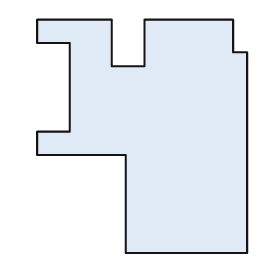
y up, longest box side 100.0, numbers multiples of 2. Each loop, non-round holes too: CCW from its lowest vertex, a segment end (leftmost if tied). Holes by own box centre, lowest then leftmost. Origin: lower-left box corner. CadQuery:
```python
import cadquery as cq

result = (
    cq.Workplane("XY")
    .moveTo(38.0, 0.0)
    .lineTo(90.0, 0.0)
    .lineTo(90.0, 86.0)
    .lineTo(84.0, 86.0)
    .lineTo(84.0, 100.0)
    .lineTo(46.0, 100.0)
    .lineTo(46.0, 80.0)
    .lineTo(32.0, 80.0)
    .lineTo(32.0, 100.0)
    .lineTo(0.0, 100.0)
    .lineTo(0.0, 90.0)
    .lineTo(14.0, 90.0)
    .lineTo(14.0, 52.0)
    .lineTo(0.0, 52.0)
    .lineTo(0.0, 42.0)
    .lineTo(38.0, 42.0)
    .close()
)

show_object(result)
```